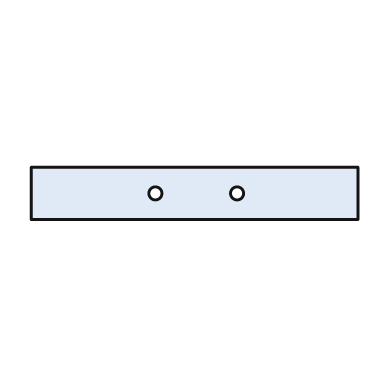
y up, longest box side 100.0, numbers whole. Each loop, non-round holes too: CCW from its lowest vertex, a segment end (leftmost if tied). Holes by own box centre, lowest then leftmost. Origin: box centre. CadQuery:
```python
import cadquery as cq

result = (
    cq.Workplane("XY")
    .moveTo(-50.0, -8.0)
    .lineTo(50.0, -8.0)
    .lineTo(50.0, 8.0)
    .lineTo(-50.0, 8.0)
    .close()
    .moveTo(-12.0, 0.0)
    .circle(2.0)
    .moveTo(13.0, 0.0)
    .circle(2.0)
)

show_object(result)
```